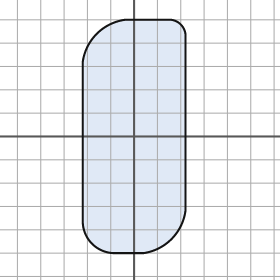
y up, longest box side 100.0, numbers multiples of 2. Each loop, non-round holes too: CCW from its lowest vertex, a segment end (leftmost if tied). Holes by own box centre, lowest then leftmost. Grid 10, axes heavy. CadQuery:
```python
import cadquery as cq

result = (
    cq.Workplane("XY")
    .moveTo(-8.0, -50.0)
    .lineTo(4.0, -50.0)
    .threePointArc((16.0, -44.0), (22.0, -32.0))
    .lineTo(22.0, 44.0)
    .threePointArc((20.0, 48.0), (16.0, 50.0))
    .lineTo(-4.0, 50.0)
    .threePointArc((-16.0, 44.0), (-22.0, 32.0))
    .lineTo(-22.0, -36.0)
    .threePointArc((-18.0, -46.0), (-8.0, -50.0))
    .close()
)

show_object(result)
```